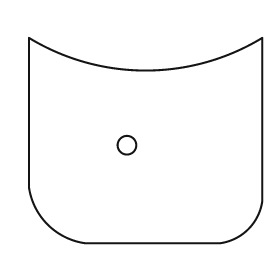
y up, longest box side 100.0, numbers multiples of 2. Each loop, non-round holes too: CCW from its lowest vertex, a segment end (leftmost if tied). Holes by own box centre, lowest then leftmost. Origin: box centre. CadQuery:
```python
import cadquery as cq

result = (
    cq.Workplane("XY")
    .moveTo(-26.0, -44.0)
    .lineTo(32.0, -44.0)
    .threePointArc((44.0, -38.0), (50.0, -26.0))
    .lineTo(50.0, 44.0)
    .threePointArc((0.0, 30.0), (-50.0, 44.0))
    .lineTo(-50.0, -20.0)
    .threePointArc((-42.0, -36.0), (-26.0, -44.0))
    .close()
    .moveTo(-8.0, -2.0)
    .circle(4.0)
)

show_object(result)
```